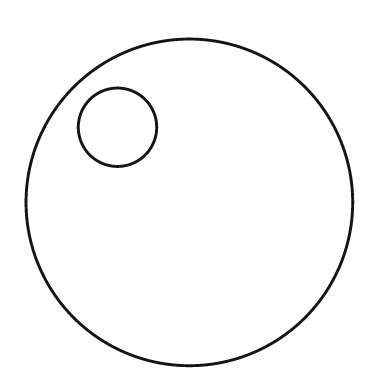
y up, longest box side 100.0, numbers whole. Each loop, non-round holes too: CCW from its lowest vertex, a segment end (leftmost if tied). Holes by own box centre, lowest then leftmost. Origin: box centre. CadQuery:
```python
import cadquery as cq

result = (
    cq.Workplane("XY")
    .moveTo(0.0, 0.0)
    .circle(50.0)
    .moveTo(-22.0, 23.0)
    .circle(12.0)
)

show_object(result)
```